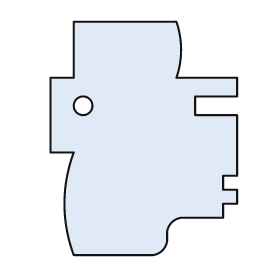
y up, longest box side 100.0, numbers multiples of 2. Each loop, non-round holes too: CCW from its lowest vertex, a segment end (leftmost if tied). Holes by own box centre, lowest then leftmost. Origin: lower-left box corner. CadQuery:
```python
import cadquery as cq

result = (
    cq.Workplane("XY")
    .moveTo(10.0, 0.0)
    .lineTo(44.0, 0.0)
    .threePointArc((48.0, 2.0), (50.0, 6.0))
    .lineTo(50.0, 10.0)
    .threePointArc((52.0, 14.0), (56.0, 16.0))
    .lineTo(74.0, 16.0)
    .lineTo(74.0, 22.0)
    .lineTo(80.0, 22.0)
    .lineTo(80.0, 28.0)
    .lineTo(74.0, 28.0)
    .lineTo(74.0, 34.0)
    .lineTo(80.0, 34.0)
    .lineTo(80.0, 60.0)
    .lineTo(62.0, 60.0)
    .lineTo(62.0, 68.0)
    .lineTo(80.0, 68.0)
    .lineTo(80.0, 76.0)
    .lineTo(54.0, 76.0)
    .threePointArc((56.0, 88.0), (54.0, 100.0))
    .lineTo(10.0, 100.0)
    .lineTo(10.0, 76.0)
    .lineTo(0.0, 76.0)
    .lineTo(0.0, 44.0)
    .lineTo(10.0, 44.0)
    .threePointArc((6.0, 22.0), (10.0, 0.0))
    .close()
    .moveTo(14.0, 64.0)
    .circle(4.0)
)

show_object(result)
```